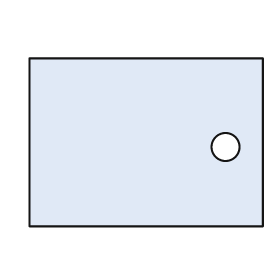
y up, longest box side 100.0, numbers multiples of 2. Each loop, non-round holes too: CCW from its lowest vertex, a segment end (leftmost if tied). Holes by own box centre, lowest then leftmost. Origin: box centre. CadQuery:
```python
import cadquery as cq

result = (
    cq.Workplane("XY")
    .moveTo(-50.0, -36.0)
    .lineTo(50.0, -36.0)
    .lineTo(50.0, 36.0)
    .lineTo(-50.0, 36.0)
    .close()
    .moveTo(34.0, -2.0)
    .circle(6.0)
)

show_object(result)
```